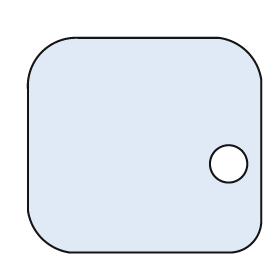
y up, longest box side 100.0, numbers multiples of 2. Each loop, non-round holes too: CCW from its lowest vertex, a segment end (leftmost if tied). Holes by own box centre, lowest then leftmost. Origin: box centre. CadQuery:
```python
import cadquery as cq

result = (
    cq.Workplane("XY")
    .moveTo(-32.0, -46.0)
    .lineTo(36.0, -46.0)
    .threePointArc((46.0, -42.0), (50.0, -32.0))
    .lineTo(50.0, 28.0)
    .threePointArc((44.0, 40.0), (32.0, 46.0))
    .lineTo(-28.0, 46.0)
    .threePointArc((-44.0, 40.0), (-50.0, 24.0))
    .lineTo(-50.0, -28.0)
    .threePointArc((-44.0, -40.0), (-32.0, -46.0))
    .close()
    .moveTo(36.0, -8.0)
    .circle(8.0)
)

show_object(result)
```